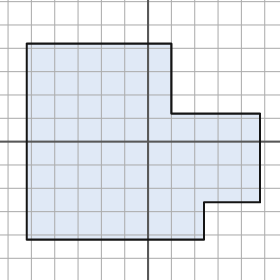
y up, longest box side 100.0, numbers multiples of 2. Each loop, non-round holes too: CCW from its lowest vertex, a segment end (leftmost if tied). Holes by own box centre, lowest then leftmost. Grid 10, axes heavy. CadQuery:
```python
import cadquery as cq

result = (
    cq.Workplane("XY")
    .moveTo(-52.0, -42.0)
    .lineTo(24.0, -42.0)
    .lineTo(24.0, -26.0)
    .lineTo(48.0, -26.0)
    .lineTo(48.0, 12.0)
    .lineTo(10.0, 12.0)
    .lineTo(10.0, 42.0)
    .lineTo(-52.0, 42.0)
    .close()
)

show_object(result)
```